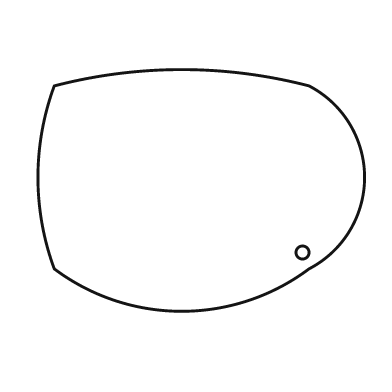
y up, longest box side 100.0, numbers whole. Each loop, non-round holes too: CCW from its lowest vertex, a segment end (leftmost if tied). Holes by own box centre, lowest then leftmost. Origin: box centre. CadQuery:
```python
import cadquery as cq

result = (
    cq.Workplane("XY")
    .moveTo(-45.0, -24.0)
    .threePointArc((-6.0, -37.0), (33.0, -24.0))
    .threePointArc((50.0, 4.0), (33.0, 32.0))
    .threePointArc((-6.0, 37.0), (-45.0, 32.0))
    .threePointArc((-50.0, 4.0), (-45.0, -24.0))
    .close()
    .moveTo(31.0, -19.0)
    .circle(2.0)
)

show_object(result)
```